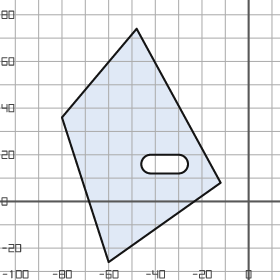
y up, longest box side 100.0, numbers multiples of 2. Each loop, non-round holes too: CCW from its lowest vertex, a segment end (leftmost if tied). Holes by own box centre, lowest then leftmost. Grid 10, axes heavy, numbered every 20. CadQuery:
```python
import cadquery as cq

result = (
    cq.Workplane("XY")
    .moveTo(-60.0, -26.0)
    .lineTo(-12.0, 8.0)
    .lineTo(-48.0, 74.0)
    .lineTo(-80.0, 36.0)
    .close()
    .moveTo(-42.0, 12.0)
    .lineTo(-30.0, 12.0)
    .threePointArc((-26.0, 16.0), (-30.0, 20.0))
    .lineTo(-42.0, 20.0)
    .threePointArc((-46.0, 16.0), (-42.0, 12.0))
    .close()
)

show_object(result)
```